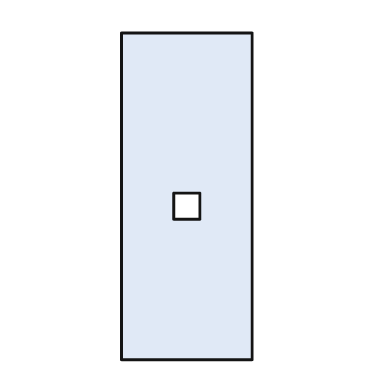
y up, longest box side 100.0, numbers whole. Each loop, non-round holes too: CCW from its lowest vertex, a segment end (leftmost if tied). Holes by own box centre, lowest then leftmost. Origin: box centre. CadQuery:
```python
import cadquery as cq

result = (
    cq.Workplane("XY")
    .moveTo(-20.0, -50.0)
    .lineTo(20.0, -50.0)
    .lineTo(20.0, 50.0)
    .lineTo(-20.0, 50.0)
    .close()
    .moveTo(-4.0, -7.0)
    .lineTo(4.0, -7.0)
    .lineTo(4.0, 1.0)
    .lineTo(-4.0, 1.0)
    .close()
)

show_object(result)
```